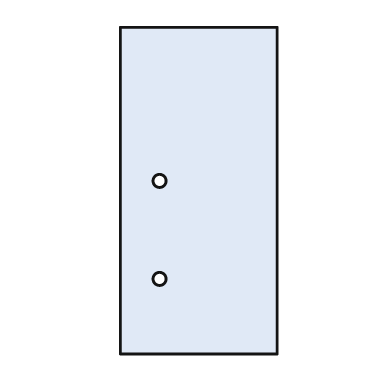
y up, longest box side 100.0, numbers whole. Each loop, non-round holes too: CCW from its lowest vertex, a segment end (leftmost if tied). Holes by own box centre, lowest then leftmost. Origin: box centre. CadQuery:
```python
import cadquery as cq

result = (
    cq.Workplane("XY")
    .moveTo(-24.0, -50.0)
    .lineTo(24.0, -50.0)
    .lineTo(24.0, 50.0)
    .lineTo(-24.0, 50.0)
    .close()
    .moveTo(-12.0, -27.0)
    .circle(2.0)
    .moveTo(-12.0, 3.0)
    .circle(2.0)
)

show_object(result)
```